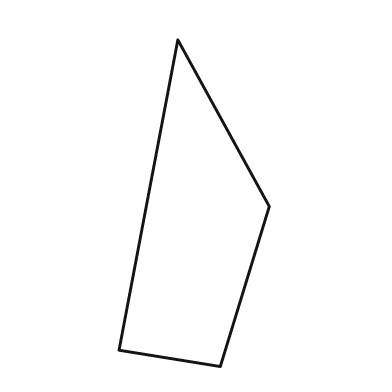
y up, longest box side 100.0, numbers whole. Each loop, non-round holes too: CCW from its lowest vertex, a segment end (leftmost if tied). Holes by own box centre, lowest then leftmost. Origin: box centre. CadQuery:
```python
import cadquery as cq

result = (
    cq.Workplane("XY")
    .moveTo(8.0, -50.0)
    .lineTo(23.0, -1.0)
    .lineTo(-5.0, 50.0)
    .lineTo(-23.0, -45.0)
    .close()
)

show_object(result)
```